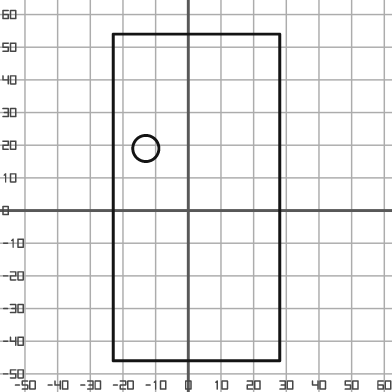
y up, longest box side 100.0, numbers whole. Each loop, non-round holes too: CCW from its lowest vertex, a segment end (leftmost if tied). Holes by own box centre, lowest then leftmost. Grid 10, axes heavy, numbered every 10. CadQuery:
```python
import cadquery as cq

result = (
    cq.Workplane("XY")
    .moveTo(-23.0, -46.0)
    .lineTo(28.0, -46.0)
    .lineTo(28.0, 54.0)
    .lineTo(-23.0, 54.0)
    .close()
    .moveTo(-13.0, 19.0)
    .circle(4.0)
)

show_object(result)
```